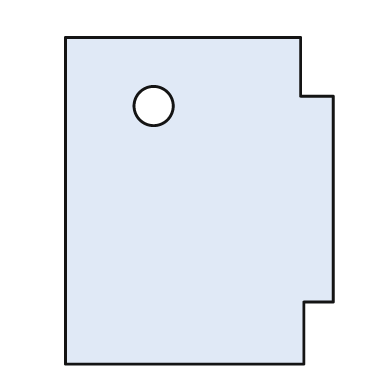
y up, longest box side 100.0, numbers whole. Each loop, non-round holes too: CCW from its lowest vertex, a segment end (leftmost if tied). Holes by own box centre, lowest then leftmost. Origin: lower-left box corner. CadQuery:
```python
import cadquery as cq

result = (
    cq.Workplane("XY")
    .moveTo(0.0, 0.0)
    .lineTo(73.0, 0.0)
    .lineTo(73.0, 19.0)
    .lineTo(82.0, 19.0)
    .lineTo(82.0, 82.0)
    .lineTo(72.0, 82.0)
    .lineTo(72.0, 100.0)
    .lineTo(0.0, 100.0)
    .close()
    .moveTo(27.0, 79.0)
    .circle(6.0)
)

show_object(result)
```